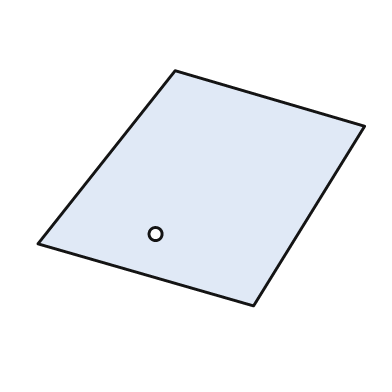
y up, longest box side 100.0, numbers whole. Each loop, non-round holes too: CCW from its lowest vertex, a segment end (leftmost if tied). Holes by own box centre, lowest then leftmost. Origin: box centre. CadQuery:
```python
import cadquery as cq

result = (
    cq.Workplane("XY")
    .moveTo(16.0, -36.0)
    .lineTo(50.0, 19.0)
    .lineTo(-8.0, 36.0)
    .lineTo(-50.0, -17.0)
    .close()
    .moveTo(-14.0, -14.0)
    .circle(2.0)
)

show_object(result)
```